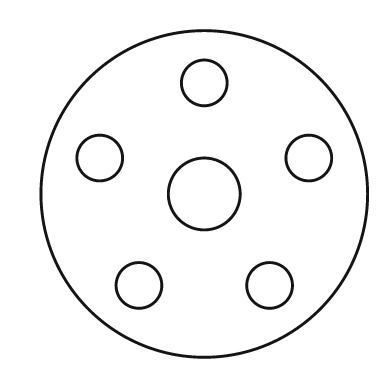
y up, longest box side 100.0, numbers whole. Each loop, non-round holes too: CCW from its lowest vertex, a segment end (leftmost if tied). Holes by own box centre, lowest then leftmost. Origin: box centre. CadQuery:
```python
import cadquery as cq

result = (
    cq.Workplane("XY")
    .moveTo(0.0, 0.0)
    .circle(50.0)
    .moveTo(-20.0, -28.0)
    .circle(7.0)
    .moveTo(20.0, -28.0)
    .circle(7.0)
    .moveTo(0.0, 0.0)
    .circle(11.0)
    .moveTo(-32.0, 11.0)
    .circle(7.0)
    .moveTo(32.0, 11.0)
    .circle(7.0)
    .moveTo(0.0, 34.0)
    .circle(7.0)
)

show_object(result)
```